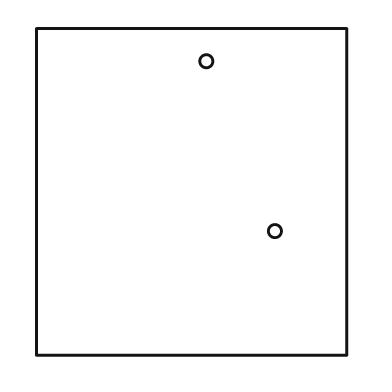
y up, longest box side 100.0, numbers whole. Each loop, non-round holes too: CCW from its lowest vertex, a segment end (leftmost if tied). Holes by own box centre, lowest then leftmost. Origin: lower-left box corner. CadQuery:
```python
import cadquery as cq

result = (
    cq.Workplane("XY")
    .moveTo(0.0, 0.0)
    .lineTo(95.0, 0.0)
    .lineTo(95.0, 100.0)
    .lineTo(0.0, 100.0)
    .close()
    .moveTo(73.0, 38.0)
    .circle(2.0)
    .moveTo(52.0, 90.0)
    .circle(2.0)
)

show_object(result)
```